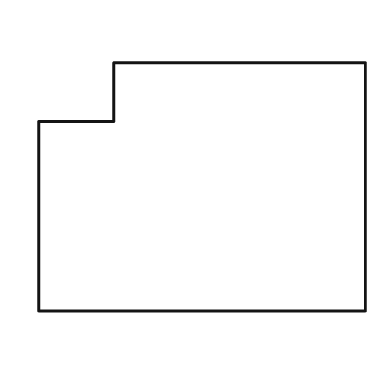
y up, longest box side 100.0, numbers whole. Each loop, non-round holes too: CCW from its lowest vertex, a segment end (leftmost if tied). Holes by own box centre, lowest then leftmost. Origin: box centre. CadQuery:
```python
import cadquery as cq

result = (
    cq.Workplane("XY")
    .moveTo(-50.0, -38.0)
    .lineTo(50.0, -38.0)
    .lineTo(50.0, 38.0)
    .lineTo(-27.0, 38.0)
    .lineTo(-27.0, 20.0)
    .lineTo(-50.0, 20.0)
    .close()
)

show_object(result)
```